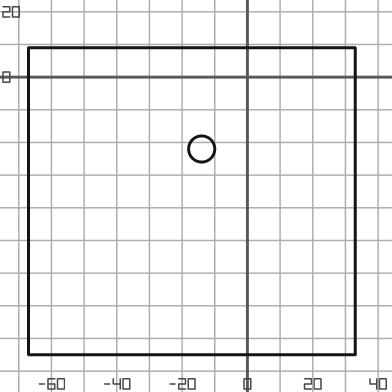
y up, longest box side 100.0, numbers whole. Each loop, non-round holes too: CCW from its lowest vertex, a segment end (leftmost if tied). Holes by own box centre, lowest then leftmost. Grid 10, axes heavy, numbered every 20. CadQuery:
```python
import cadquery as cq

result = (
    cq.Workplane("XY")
    .moveTo(-67.0, -85.0)
    .lineTo(33.0, -85.0)
    .lineTo(33.0, 9.0)
    .lineTo(-67.0, 9.0)
    .close()
    .moveTo(-14.0, -22.0)
    .circle(4.0)
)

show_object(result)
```